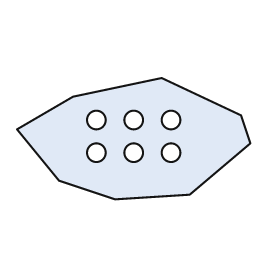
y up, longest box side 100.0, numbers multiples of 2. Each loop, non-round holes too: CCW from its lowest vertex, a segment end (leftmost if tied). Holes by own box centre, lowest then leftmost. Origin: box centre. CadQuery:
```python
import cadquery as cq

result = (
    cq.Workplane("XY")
    .moveTo(-8.0, -26.0)
    .lineTo(24.0, -24.0)
    .lineTo(50.0, -2.0)
    .lineTo(46.0, 10.0)
    .lineTo(12.0, 26.0)
    .lineTo(-26.0, 18.0)
    .lineTo(-50.0, 4.0)
    .lineTo(-32.0, -18.0)
    .close()
    .moveTo(-16.0, -6.0)
    .circle(4.0)
    .moveTo(0.0, -6.0)
    .circle(4.0)
    .moveTo(16.0, -6.0)
    .circle(4.0)
    .moveTo(-16.0, 8.0)
    .circle(4.0)
    .moveTo(0.0, 8.0)
    .circle(4.0)
    .moveTo(16.0, 8.0)
    .circle(4.0)
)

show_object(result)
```